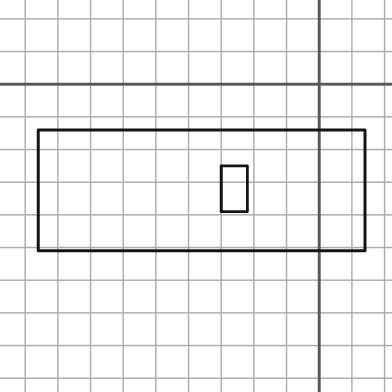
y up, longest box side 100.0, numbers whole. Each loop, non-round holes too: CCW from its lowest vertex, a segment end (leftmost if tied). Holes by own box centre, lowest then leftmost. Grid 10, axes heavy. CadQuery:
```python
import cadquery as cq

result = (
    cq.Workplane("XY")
    .moveTo(-86.0, -51.0)
    .lineTo(14.0, -51.0)
    .lineTo(14.0, -14.0)
    .lineTo(-86.0, -14.0)
    .close()
    .moveTo(-30.0, -39.0)
    .lineTo(-22.0, -39.0)
    .lineTo(-22.0, -25.0)
    .lineTo(-30.0, -25.0)
    .close()
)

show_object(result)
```